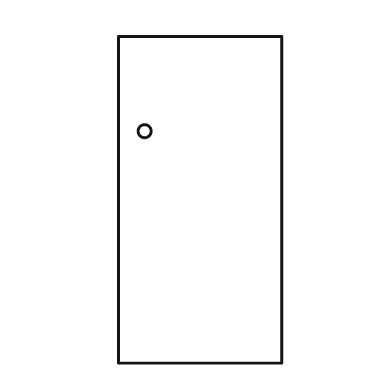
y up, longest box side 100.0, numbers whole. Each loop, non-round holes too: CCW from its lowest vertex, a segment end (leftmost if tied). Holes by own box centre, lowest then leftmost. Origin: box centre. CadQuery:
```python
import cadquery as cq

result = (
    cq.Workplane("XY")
    .moveTo(-25.0, -50.0)
    .lineTo(25.0, -50.0)
    .lineTo(25.0, 50.0)
    .lineTo(-25.0, 50.0)
    .close()
    .moveTo(-17.0, 21.0)
    .circle(2.0)
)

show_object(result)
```